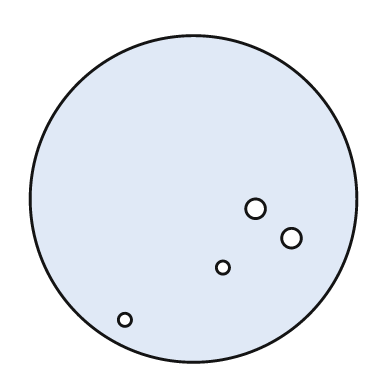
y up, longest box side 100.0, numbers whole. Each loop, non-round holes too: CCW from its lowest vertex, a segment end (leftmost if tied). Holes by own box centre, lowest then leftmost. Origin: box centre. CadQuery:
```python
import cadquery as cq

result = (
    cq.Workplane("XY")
    .moveTo(0.0, 0.0)
    .circle(50.0)
    .moveTo(-21.0, -37.0)
    .circle(2.0)
    .moveTo(9.0, -21.0)
    .circle(2.0)
    .moveTo(30.0, -12.0)
    .circle(3.0)
    .moveTo(19.0, -3.0)
    .circle(3.0)
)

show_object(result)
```